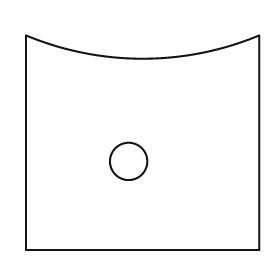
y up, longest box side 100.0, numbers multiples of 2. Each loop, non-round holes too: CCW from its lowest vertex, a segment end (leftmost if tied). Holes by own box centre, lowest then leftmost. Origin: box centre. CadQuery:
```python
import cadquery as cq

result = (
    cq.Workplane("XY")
    .moveTo(-50.0, -46.0)
    .lineTo(50.0, -46.0)
    .lineTo(50.0, 46.0)
    .threePointArc((0.0, 36.0), (-50.0, 46.0))
    .close()
    .moveTo(-6.0, -8.0)
    .circle(8.0)
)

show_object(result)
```